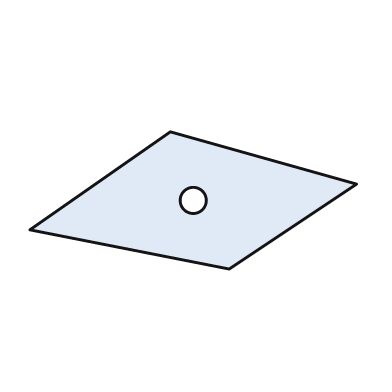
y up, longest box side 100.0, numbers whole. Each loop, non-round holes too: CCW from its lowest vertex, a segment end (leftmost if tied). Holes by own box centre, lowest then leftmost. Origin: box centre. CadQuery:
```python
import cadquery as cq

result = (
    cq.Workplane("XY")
    .moveTo(11.0, -21.0)
    .lineTo(50.0, 5.0)
    .lineTo(-7.0, 21.0)
    .lineTo(-50.0, -9.0)
    .close()
    .moveTo(0.0, 0.0)
    .circle(4.0)
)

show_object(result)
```